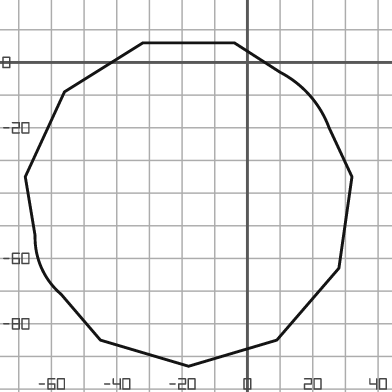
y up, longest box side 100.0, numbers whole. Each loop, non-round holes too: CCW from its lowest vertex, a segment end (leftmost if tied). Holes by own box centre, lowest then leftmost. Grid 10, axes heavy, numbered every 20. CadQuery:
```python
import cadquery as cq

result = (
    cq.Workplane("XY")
    .moveTo(-18.0, -93.0)
    .lineTo(9.0, -85.0)
    .lineTo(28.0, -63.0)
    .lineTo(32.0, -35.0)
    .lineTo(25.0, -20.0)
    .threePointArc((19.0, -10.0), (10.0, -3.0))
    .lineTo(-4.0, 6.0)
    .lineTo(-32.0, 6.0)
    .lineTo(-56.0, -9.0)
    .lineTo(-68.0, -35.0)
    .lineTo(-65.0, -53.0)
    .threePointArc((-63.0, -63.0), (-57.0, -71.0))
    .lineTo(-45.0, -85.0)
    .close()
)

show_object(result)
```